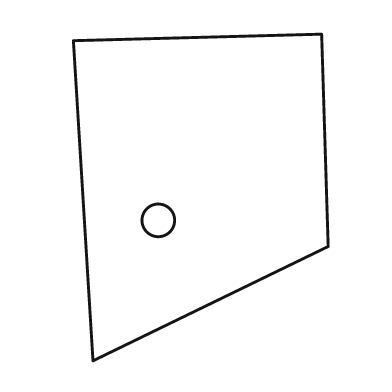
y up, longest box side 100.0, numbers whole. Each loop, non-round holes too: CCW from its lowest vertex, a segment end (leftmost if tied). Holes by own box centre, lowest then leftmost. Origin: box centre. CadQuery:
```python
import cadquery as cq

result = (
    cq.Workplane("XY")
    .moveTo(-33.0, -50.0)
    .lineTo(39.0, -15.0)
    .lineTo(37.0, 50.0)
    .lineTo(-39.0, 48.0)
    .close()
    .moveTo(-13.0, -7.0)
    .circle(5.0)
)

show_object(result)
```